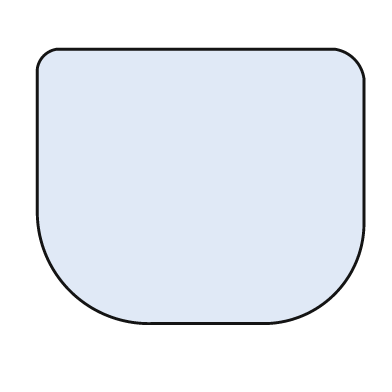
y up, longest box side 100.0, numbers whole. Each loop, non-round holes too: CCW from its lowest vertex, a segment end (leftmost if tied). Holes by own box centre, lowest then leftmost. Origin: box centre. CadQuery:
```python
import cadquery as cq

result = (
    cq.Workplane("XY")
    .moveTo(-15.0, -42.0)
    .lineTo(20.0, -42.0)
    .threePointArc((41.0, -33.0), (50.0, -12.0))
    .lineTo(50.0, 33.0)
    .threePointArc((47.0, 39.0), (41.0, 42.0))
    .lineTo(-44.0, 42.0)
    .threePointArc((-48.0, 40.0), (-50.0, 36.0))
    .lineTo(-50.0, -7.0)
    .threePointArc((-40.0, -32.0), (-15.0, -42.0))
    .close()
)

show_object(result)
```